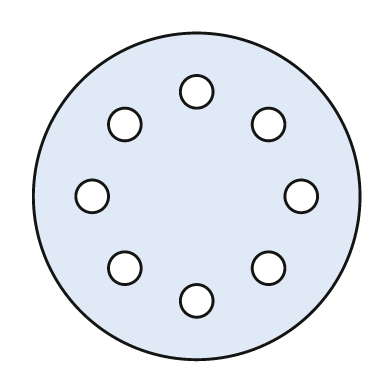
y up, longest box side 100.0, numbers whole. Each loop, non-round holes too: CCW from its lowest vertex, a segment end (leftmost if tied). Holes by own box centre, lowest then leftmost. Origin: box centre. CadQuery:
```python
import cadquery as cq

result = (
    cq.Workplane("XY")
    .moveTo(0.0, 0.0)
    .circle(50.0)
    .moveTo(0.0, -32.0)
    .circle(5.0)
    .moveTo(-22.0, -22.0)
    .circle(5.0)
    .moveTo(22.0, -22.0)
    .circle(5.0)
    .moveTo(-32.0, 0.0)
    .circle(5.0)
    .moveTo(32.0, 0.0)
    .circle(5.0)
    .moveTo(-22.0, 22.0)
    .circle(5.0)
    .moveTo(22.0, 22.0)
    .circle(5.0)
    .moveTo(0.0, 32.0)
    .circle(5.0)
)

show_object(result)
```